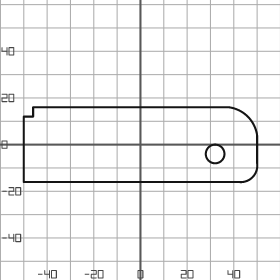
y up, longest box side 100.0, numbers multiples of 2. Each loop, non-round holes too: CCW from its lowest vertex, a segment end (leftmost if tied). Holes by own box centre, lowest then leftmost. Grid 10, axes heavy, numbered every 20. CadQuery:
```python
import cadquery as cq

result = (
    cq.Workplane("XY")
    .moveTo(-50.0, -16.0)
    .lineTo(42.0, -16.0)
    .threePointArc((48.0, -14.0), (50.0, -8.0))
    .lineTo(50.0, 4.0)
    .threePointArc((46.0, 12.0), (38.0, 16.0))
    .lineTo(-46.0, 16.0)
    .lineTo(-46.0, 12.0)
    .lineTo(-50.0, 12.0)
    .close()
    .moveTo(32.0, -4.0)
    .circle(4.0)
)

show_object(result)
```